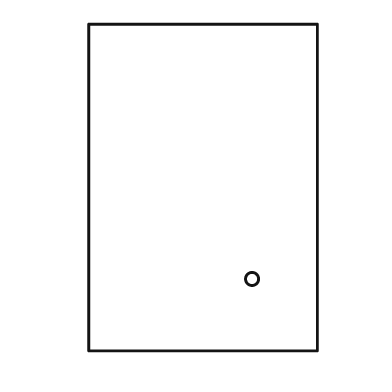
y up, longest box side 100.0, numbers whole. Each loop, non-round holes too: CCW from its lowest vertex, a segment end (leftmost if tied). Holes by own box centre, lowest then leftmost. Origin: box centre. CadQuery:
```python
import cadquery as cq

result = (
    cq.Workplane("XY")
    .moveTo(-35.0, -50.0)
    .lineTo(35.0, -50.0)
    .lineTo(35.0, 50.0)
    .lineTo(-35.0, 50.0)
    .close()
    .moveTo(15.0, -28.0)
    .circle(2.0)
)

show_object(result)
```